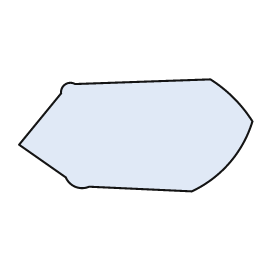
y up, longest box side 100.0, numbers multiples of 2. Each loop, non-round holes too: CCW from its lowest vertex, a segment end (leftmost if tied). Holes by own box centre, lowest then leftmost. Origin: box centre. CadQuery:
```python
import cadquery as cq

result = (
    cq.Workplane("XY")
    .moveTo(24.0, -24.0)
    .threePointArc((40.0, -12.0), (50.0, 6.0))
    .threePointArc((42.0, 16.0), (32.0, 24.0))
    .lineTo(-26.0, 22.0)
    .threePointArc((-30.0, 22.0), (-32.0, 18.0))
    .lineTo(-50.0, -4.0)
    .lineTo(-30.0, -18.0)
    .threePointArc((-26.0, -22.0), (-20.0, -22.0))
    .close()
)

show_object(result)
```